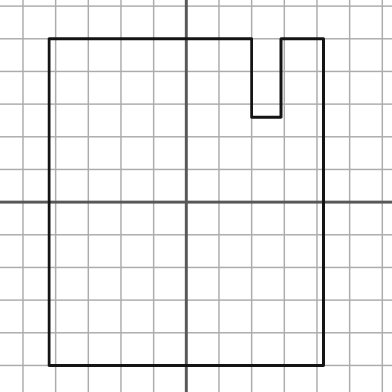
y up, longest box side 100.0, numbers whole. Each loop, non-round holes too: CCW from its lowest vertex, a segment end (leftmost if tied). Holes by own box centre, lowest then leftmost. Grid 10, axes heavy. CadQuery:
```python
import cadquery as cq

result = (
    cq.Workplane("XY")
    .moveTo(-42.0, -50.0)
    .lineTo(42.0, -50.0)
    .lineTo(42.0, 50.0)
    .lineTo(29.0, 50.0)
    .lineTo(29.0, 26.0)
    .lineTo(20.0, 26.0)
    .lineTo(20.0, 50.0)
    .lineTo(-42.0, 50.0)
    .close()
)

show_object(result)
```